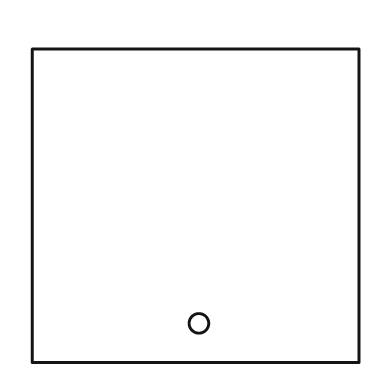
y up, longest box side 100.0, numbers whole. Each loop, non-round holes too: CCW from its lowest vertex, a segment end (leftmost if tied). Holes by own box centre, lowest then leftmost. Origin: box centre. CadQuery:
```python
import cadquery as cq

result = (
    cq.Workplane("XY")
    .moveTo(-50.0, -48.0)
    .lineTo(50.0, -48.0)
    .lineTo(50.0, 48.0)
    .lineTo(-50.0, 48.0)
    .close()
    .moveTo(1.0, -36.0)
    .circle(3.0)
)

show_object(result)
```